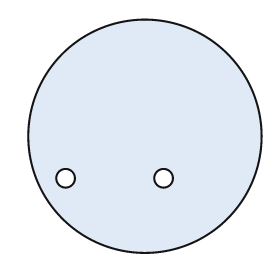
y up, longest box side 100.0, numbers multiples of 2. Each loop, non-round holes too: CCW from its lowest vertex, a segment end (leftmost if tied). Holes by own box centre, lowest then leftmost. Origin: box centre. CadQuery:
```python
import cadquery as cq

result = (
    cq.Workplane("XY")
    .moveTo(0.0, 0.0)
    .circle(50.0)
    .moveTo(-34.0, -18.0)
    .circle(4.0)
    .moveTo(8.0, -18.0)
    .circle(4.0)
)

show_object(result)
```